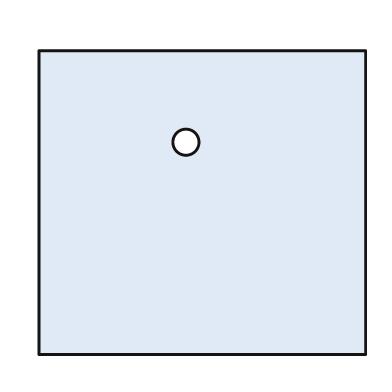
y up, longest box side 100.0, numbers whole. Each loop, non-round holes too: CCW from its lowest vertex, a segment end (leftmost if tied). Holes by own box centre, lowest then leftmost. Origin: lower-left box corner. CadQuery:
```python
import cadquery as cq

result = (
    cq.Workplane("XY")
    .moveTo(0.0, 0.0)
    .lineTo(100.0, 0.0)
    .lineTo(100.0, 93.0)
    .lineTo(0.0, 93.0)
    .close()
    .moveTo(45.0, 65.0)
    .circle(4.0)
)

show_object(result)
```